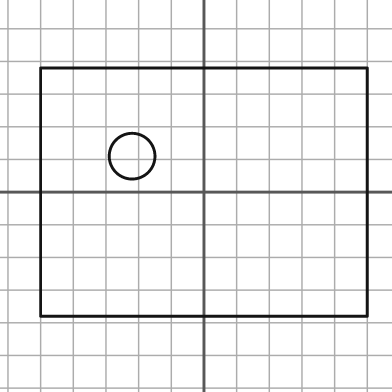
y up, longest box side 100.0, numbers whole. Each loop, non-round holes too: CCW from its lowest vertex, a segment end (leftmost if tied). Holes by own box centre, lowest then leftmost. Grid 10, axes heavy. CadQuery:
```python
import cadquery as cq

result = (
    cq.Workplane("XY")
    .moveTo(-50.0, -38.0)
    .lineTo(50.0, -38.0)
    .lineTo(50.0, 38.0)
    .lineTo(-50.0, 38.0)
    .close()
    .moveTo(-22.0, 11.0)
    .circle(7.0)
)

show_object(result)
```